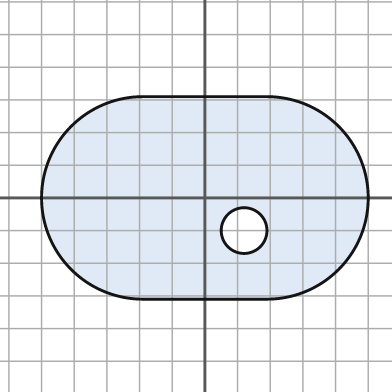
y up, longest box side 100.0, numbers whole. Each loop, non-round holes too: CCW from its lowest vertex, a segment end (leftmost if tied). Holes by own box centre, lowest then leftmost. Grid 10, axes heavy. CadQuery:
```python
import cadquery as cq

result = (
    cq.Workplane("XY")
    .moveTo(-19.0, -31.0)
    .lineTo(19.0, -31.0)
    .threePointArc((50.0, 0.0), (19.0, 31.0))
    .lineTo(-19.0, 31.0)
    .threePointArc((-50.0, 0.0), (-19.0, -31.0))
    .close()
    .moveTo(12.0, -10.0)
    .circle(7.0)
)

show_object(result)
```